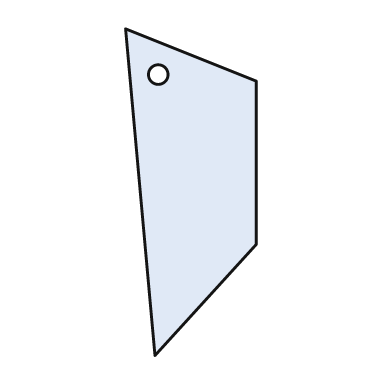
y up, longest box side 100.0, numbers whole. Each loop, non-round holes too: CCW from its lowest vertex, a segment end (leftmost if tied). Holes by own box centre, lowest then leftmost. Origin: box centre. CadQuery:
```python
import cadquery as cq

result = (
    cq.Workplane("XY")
    .moveTo(-11.0, -50.0)
    .lineTo(20.0, -16.0)
    .lineTo(20.0, 34.0)
    .lineTo(-20.0, 50.0)
    .close()
    .moveTo(-10.0, 36.0)
    .circle(3.0)
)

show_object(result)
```